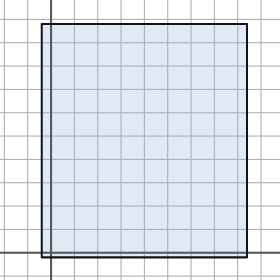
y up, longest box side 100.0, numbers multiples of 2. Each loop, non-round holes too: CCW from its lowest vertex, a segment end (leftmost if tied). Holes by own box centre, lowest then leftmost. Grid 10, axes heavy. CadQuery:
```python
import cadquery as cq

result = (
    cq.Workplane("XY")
    .moveTo(-4.0, -2.0)
    .lineTo(84.0, -2.0)
    .lineTo(84.0, 98.0)
    .lineTo(-4.0, 98.0)
    .close()
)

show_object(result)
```